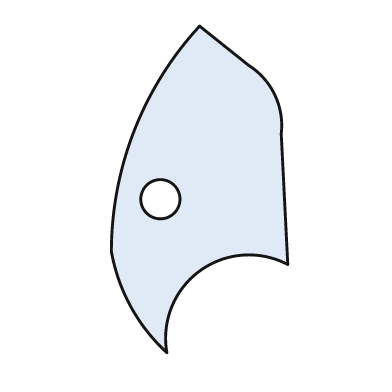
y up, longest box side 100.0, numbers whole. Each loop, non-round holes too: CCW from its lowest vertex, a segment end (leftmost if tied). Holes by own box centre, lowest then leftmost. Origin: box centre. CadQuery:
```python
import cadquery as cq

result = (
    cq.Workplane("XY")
    .moveTo(-10.0, -50.0)
    .threePointArc((0.0, -25.0), (27.0, -23.0))
    .lineTo(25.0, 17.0)
    .threePointArc((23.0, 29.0), (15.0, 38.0))
    .lineTo(0.0, 50.0)
    .threePointArc((-20.0, 18.0), (-27.0, -19.0))
    .threePointArc((-21.0, -36.0), (-10.0, -50.0))
    .close()
    .moveTo(-12.0, -3.0)
    .circle(6.0)
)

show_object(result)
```